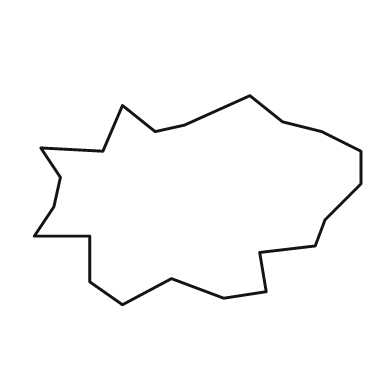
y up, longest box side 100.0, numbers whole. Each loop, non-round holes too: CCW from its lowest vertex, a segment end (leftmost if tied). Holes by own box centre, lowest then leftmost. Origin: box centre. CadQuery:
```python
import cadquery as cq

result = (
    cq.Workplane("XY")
    .moveTo(-23.0, -32.0)
    .lineTo(-8.0, -24.0)
    .lineTo(8.0, -30.0)
    .lineTo(21.0, -28.0)
    .lineTo(19.0, -16.0)
    .lineTo(36.0, -14.0)
    .lineTo(39.0, -6.0)
    .lineTo(50.0, 5.0)
    .lineTo(50.0, 15.0)
    .lineTo(38.0, 21.0)
    .lineTo(26.0, 24.0)
    .lineTo(16.0, 32.0)
    .lineTo(-4.0, 23.0)
    .lineTo(-13.0, 21.0)
    .lineTo(-23.0, 29.0)
    .lineTo(-29.0, 15.0)
    .lineTo(-48.0, 16.0)
    .lineTo(-42.0, 7.0)
    .lineTo(-44.0, -2.0)
    .lineTo(-50.0, -11.0)
    .lineTo(-33.0, -11.0)
    .lineTo(-33.0, -25.0)
    .close()
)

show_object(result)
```